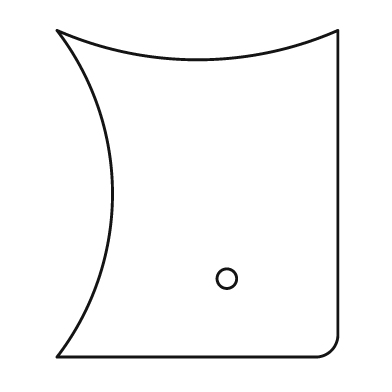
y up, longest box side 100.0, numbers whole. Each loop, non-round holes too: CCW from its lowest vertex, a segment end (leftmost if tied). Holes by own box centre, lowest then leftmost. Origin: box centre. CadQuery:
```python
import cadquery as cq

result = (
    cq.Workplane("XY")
    .moveTo(-43.0, -50.0)
    .lineTo(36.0, -50.0)
    .threePointArc((41.0, -48.0), (43.0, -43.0))
    .lineTo(43.0, 50.0)
    .threePointArc((0.0, 41.0), (-43.0, 50.0))
    .threePointArc((-26.0, 0.0), (-43.0, -50.0))
    .close()
    .moveTo(9.0, -26.0)
    .circle(3.0)
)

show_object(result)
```